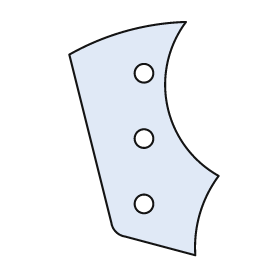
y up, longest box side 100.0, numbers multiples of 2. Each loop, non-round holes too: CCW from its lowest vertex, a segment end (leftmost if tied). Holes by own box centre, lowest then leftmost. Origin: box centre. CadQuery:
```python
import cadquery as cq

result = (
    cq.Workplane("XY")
    .moveTo(22.0, -50.0)
    .threePointArc((24.0, -32.0), (32.0, -16.0))
    .threePointArc((10.0, 14.0), (18.0, 50.0))
    .threePointArc((-8.0, 46.0), (-32.0, 36.0))
    .lineTo(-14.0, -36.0)
    .threePointArc((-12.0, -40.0), (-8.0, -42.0))
    .close()
    .moveTo(0.0, -28.0)
    .circle(4.0)
    .moveTo(0.0, 0.0)
    .circle(4.0)
    .moveTo(0.0, 28.0)
    .circle(4.0)
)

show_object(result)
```